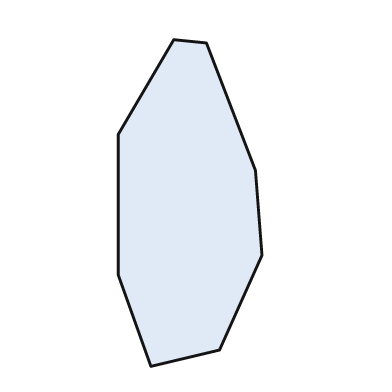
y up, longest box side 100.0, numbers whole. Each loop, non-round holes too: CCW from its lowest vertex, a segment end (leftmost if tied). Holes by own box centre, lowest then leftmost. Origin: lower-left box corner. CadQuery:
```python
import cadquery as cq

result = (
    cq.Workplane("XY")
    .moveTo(10.0, 0.0)
    .lineTo(31.0, 5.0)
    .lineTo(44.0, 34.0)
    .lineTo(42.0, 60.0)
    .lineTo(27.0, 99.0)
    .lineTo(17.0, 100.0)
    .lineTo(0.0, 71.0)
    .lineTo(0.0, 28.0)
    .close()
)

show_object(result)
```